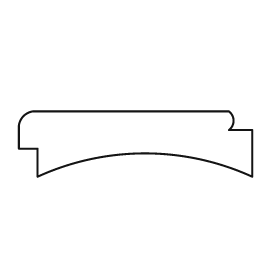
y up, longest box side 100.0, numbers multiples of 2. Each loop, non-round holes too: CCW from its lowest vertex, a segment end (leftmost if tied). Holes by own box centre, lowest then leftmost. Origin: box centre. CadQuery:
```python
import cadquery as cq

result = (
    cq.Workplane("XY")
    .moveTo(-42.0, -14.0)
    .threePointArc((4.0, -4.0), (50.0, -14.0))
    .lineTo(50.0, 6.0)
    .lineTo(40.0, 6.0)
    .threePointArc((42.0, 10.0), (40.0, 14.0))
    .lineTo(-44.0, 14.0)
    .threePointArc((-48.0, 12.0), (-50.0, 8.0))
    .lineTo(-50.0, -2.0)
    .lineTo(-42.0, -2.0)
    .close()
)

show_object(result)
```